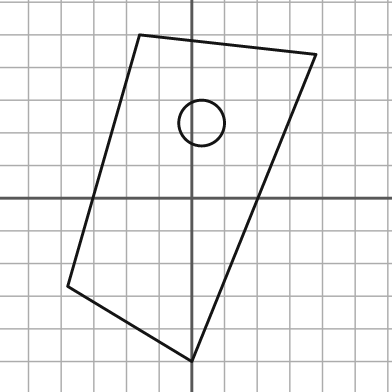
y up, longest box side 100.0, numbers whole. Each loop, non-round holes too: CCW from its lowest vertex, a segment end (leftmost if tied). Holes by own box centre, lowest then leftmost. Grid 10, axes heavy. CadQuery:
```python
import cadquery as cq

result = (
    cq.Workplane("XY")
    .moveTo(0.0, -50.0)
    .lineTo(38.0, 44.0)
    .lineTo(-16.0, 50.0)
    .lineTo(-38.0, -27.0)
    .close()
    .moveTo(3.0, 23.0)
    .circle(7.0)
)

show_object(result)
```